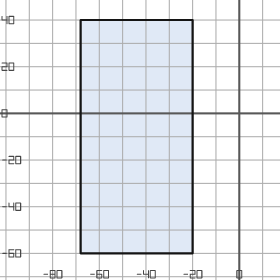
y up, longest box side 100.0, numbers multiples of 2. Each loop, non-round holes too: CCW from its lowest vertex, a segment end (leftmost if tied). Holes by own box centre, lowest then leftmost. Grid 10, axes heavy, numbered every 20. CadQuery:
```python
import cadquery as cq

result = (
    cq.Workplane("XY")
    .moveTo(-68.0, -60.0)
    .lineTo(-20.0, -60.0)
    .lineTo(-20.0, 40.0)
    .lineTo(-68.0, 40.0)
    .close()
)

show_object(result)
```